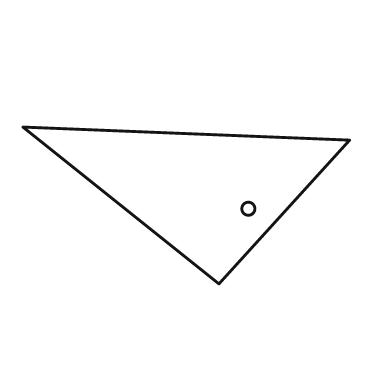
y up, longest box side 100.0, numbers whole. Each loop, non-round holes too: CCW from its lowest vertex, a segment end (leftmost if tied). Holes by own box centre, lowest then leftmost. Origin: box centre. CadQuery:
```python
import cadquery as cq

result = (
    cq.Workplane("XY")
    .moveTo(10.0, -24.0)
    .lineTo(50.0, 20.0)
    .lineTo(-50.0, 24.0)
    .close()
    .moveTo(19.0, -1.0)
    .circle(2.0)
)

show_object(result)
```